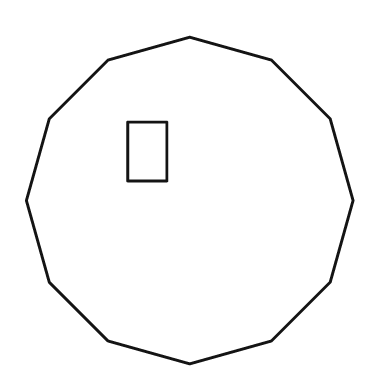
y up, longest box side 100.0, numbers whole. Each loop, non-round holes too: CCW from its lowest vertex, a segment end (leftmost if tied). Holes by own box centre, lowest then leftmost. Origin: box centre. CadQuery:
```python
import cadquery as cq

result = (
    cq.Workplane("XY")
    .moveTo(0.0, -50.0)
    .lineTo(25.0, -43.0)
    .lineTo(43.0, -25.0)
    .lineTo(50.0, 0.0)
    .lineTo(43.0, 25.0)
    .lineTo(25.0, 43.0)
    .lineTo(0.0, 50.0)
    .lineTo(-25.0, 43.0)
    .lineTo(-43.0, 25.0)
    .lineTo(-50.0, 0.0)
    .lineTo(-43.0, -25.0)
    .lineTo(-25.0, -43.0)
    .close()
    .moveTo(-19.0, 6.0)
    .lineTo(-7.0, 6.0)
    .lineTo(-7.0, 24.0)
    .lineTo(-19.0, 24.0)
    .close()
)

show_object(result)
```